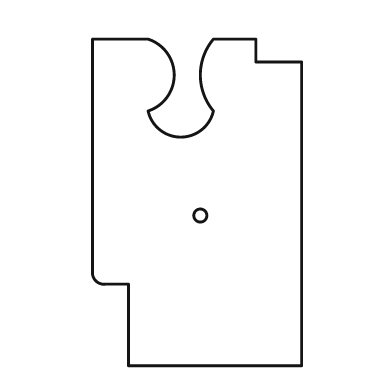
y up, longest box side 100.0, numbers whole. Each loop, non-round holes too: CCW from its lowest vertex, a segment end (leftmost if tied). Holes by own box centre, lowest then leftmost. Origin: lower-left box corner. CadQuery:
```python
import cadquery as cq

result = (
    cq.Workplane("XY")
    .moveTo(11.0, 0.0)
    .lineTo(64.0, 0.0)
    .lineTo(64.0, 93.0)
    .lineTo(50.0, 93.0)
    .lineTo(50.0, 100.0)
    .lineTo(37.0, 100.0)
    .threePointArc((33.0, 89.0), (37.0, 78.0))
    .threePointArc((27.0, 70.0), (17.0, 78.0))
    .threePointArc((25.0, 89.0), (17.0, 100.0))
    .lineTo(0.0, 100.0)
    .lineTo(0.0, 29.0)
    .threePointArc((1.0, 26.0), (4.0, 25.0))
    .lineTo(11.0, 25.0)
    .close()
    .moveTo(33.0, 46.0)
    .circle(2.0)
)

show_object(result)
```